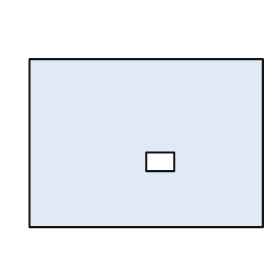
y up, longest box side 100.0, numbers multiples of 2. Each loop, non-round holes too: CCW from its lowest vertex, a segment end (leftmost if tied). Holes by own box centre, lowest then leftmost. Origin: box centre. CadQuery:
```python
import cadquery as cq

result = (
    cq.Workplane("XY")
    .moveTo(-50.0, -36.0)
    .lineTo(50.0, -36.0)
    .lineTo(50.0, 36.0)
    .lineTo(-50.0, 36.0)
    .close()
    .moveTo(0.0, -12.0)
    .lineTo(12.0, -12.0)
    .lineTo(12.0, -4.0)
    .lineTo(0.0, -4.0)
    .close()
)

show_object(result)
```